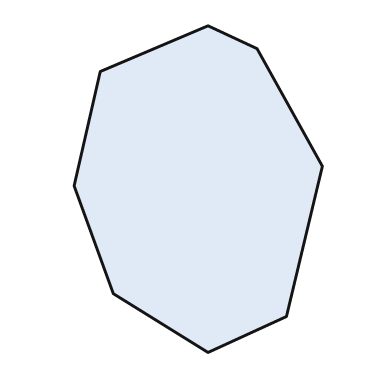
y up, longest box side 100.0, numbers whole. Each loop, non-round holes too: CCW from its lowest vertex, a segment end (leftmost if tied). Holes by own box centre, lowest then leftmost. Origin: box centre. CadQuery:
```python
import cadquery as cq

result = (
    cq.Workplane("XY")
    .moveTo(3.0, -50.0)
    .lineTo(27.0, -39.0)
    .lineTo(38.0, 7.0)
    .lineTo(18.0, 43.0)
    .lineTo(3.0, 50.0)
    .lineTo(-30.0, 36.0)
    .lineTo(-38.0, 1.0)
    .lineTo(-26.0, -32.0)
    .close()
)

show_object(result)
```